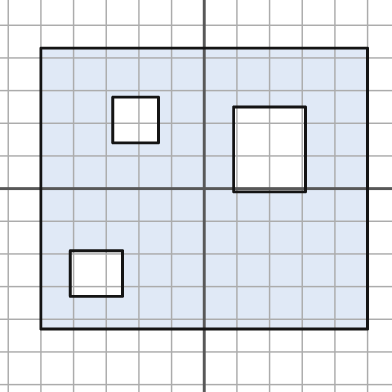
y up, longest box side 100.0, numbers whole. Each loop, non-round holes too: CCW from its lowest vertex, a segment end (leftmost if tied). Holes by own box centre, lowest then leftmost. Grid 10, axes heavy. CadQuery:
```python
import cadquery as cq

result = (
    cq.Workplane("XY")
    .moveTo(-50.0, -43.0)
    .lineTo(50.0, -43.0)
    .lineTo(50.0, 43.0)
    .lineTo(-50.0, 43.0)
    .close()
    .moveTo(-41.0, -33.0)
    .lineTo(-25.0, -33.0)
    .lineTo(-25.0, -19.0)
    .lineTo(-41.0, -19.0)
    .close()
    .moveTo(9.0, -1.0)
    .lineTo(31.0, -1.0)
    .lineTo(31.0, 25.0)
    .lineTo(9.0, 25.0)
    .close()
    .moveTo(-28.0, 14.0)
    .lineTo(-14.0, 14.0)
    .lineTo(-14.0, 28.0)
    .lineTo(-28.0, 28.0)
    .close()
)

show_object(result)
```